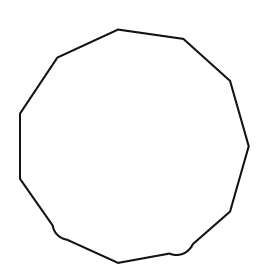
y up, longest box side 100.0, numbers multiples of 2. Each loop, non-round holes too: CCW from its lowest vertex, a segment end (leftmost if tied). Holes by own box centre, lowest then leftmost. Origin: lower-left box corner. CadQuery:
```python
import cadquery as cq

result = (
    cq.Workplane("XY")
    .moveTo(42.0, 0.0)
    .lineTo(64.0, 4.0)
    .threePointArc((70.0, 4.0), (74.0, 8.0))
    .lineTo(90.0, 22.0)
    .lineTo(98.0, 50.0)
    .lineTo(90.0, 78.0)
    .lineTo(70.0, 96.0)
    .lineTo(42.0, 100.0)
    .lineTo(16.0, 88.0)
    .lineTo(0.0, 64.0)
    .lineTo(0.0, 36.0)
    .lineTo(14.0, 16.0)
    .threePointArc((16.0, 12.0), (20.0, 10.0))
    .close()
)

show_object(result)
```